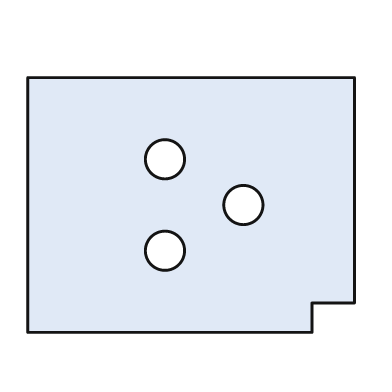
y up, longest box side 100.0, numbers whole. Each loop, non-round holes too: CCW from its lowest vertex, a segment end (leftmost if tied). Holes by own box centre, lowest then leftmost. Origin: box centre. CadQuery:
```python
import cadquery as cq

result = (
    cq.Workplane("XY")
    .moveTo(-50.0, -39.0)
    .lineTo(37.0, -39.0)
    .lineTo(37.0, -30.0)
    .lineTo(50.0, -30.0)
    .lineTo(50.0, 39.0)
    .lineTo(-50.0, 39.0)
    .close()
    .moveTo(-8.0, -14.0)
    .circle(6.0)
    .moveTo(16.0, 0.0)
    .circle(6.0)
    .moveTo(-8.0, 14.0)
    .circle(6.0)
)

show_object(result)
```